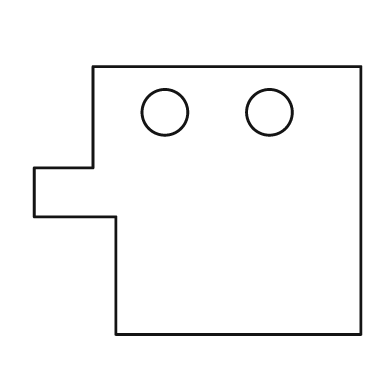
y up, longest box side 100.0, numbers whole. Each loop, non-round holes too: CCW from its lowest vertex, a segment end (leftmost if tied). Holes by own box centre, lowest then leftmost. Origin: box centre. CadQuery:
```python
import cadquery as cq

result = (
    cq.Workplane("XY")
    .moveTo(-25.0, -41.0)
    .lineTo(50.0, -41.0)
    .lineTo(50.0, 41.0)
    .lineTo(-32.0, 41.0)
    .lineTo(-32.0, 10.0)
    .lineTo(-50.0, 10.0)
    .lineTo(-50.0, -5.0)
    .lineTo(-25.0, -5.0)
    .close()
    .moveTo(-10.0, 27.0)
    .circle(7.0)
    .moveTo(22.0, 27.0)
    .circle(7.0)
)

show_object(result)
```